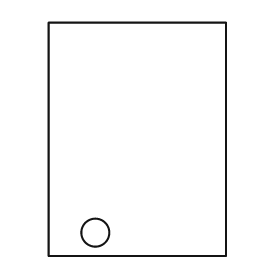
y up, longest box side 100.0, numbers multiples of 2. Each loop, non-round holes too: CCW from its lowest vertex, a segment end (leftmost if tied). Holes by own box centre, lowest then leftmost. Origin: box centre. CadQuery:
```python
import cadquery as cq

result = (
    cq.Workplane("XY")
    .moveTo(-38.0, -50.0)
    .lineTo(38.0, -50.0)
    .lineTo(38.0, 50.0)
    .lineTo(-38.0, 50.0)
    .close()
    .moveTo(-18.0, -40.0)
    .circle(6.0)
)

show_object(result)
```